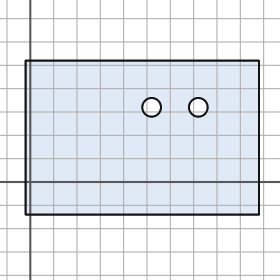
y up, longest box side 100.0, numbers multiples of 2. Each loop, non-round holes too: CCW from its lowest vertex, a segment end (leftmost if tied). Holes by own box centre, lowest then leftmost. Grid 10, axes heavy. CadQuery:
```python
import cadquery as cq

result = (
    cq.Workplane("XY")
    .moveTo(-2.0, -14.0)
    .lineTo(98.0, -14.0)
    .lineTo(98.0, 52.0)
    .lineTo(-2.0, 52.0)
    .close()
    .moveTo(52.0, 32.0)
    .circle(4.0)
    .moveTo(72.0, 32.0)
    .circle(4.0)
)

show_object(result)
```